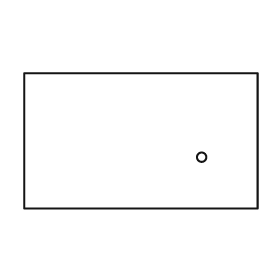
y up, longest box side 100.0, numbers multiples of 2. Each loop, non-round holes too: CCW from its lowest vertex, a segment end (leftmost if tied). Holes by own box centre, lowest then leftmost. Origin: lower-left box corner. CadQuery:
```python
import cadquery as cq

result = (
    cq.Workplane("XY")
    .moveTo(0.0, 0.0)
    .lineTo(100.0, 0.0)
    .lineTo(100.0, 58.0)
    .lineTo(0.0, 58.0)
    .close()
    .moveTo(76.0, 22.0)
    .circle(2.0)
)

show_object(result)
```